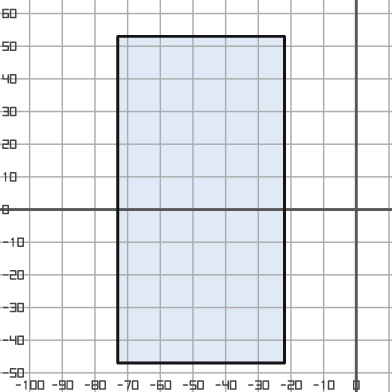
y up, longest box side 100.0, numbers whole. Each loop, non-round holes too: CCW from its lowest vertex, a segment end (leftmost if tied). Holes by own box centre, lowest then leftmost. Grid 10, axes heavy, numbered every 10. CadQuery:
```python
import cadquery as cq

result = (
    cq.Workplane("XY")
    .moveTo(-73.0, -47.0)
    .lineTo(-22.0, -47.0)
    .lineTo(-22.0, 53.0)
    .lineTo(-73.0, 53.0)
    .close()
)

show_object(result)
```